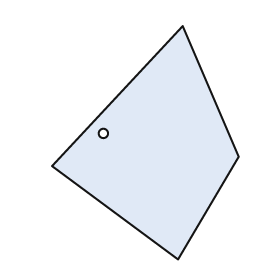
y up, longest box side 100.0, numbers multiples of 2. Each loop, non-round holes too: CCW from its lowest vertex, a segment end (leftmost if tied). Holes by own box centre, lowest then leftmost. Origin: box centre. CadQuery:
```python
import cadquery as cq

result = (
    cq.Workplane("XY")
    .moveTo(14.0, -50.0)
    .lineTo(40.0, -6.0)
    .lineTo(16.0, 50.0)
    .lineTo(-40.0, -10.0)
    .close()
    .moveTo(-18.0, 4.0)
    .circle(2.0)
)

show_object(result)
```